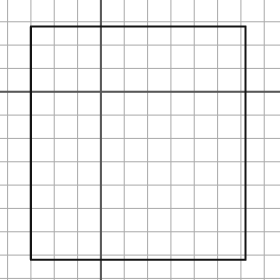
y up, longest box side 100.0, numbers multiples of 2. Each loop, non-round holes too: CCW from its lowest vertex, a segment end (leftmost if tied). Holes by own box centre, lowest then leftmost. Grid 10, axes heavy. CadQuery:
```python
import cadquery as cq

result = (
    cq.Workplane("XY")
    .moveTo(-30.0, -72.0)
    .lineTo(62.0, -72.0)
    .lineTo(62.0, 28.0)
    .lineTo(-30.0, 28.0)
    .close()
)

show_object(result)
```